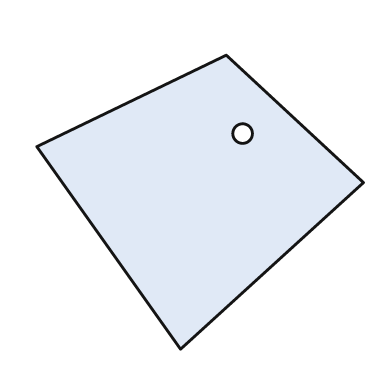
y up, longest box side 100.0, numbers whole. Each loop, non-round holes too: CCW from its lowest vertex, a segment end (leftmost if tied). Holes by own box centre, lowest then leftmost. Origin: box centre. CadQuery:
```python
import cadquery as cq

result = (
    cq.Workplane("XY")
    .moveTo(-6.0, -45.0)
    .lineTo(50.0, 6.0)
    .lineTo(8.0, 45.0)
    .lineTo(-50.0, 17.0)
    .close()
    .moveTo(13.0, 21.0)
    .circle(3.0)
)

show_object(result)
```